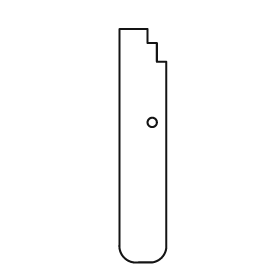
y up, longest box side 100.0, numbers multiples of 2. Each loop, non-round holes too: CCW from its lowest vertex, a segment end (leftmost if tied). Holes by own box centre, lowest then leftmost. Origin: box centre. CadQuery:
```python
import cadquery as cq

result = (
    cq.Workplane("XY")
    .moveTo(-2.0, -50.0)
    .lineTo(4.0, -50.0)
    .threePointArc((8.0, -48.0), (10.0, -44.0))
    .lineTo(10.0, 36.0)
    .lineTo(6.0, 36.0)
    .lineTo(6.0, 44.0)
    .lineTo(2.0, 44.0)
    .lineTo(2.0, 50.0)
    .lineTo(-10.0, 50.0)
    .lineTo(-10.0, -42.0)
    .threePointArc((-8.0, -48.0), (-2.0, -50.0))
    .close()
    .moveTo(4.0, 10.0)
    .circle(2.0)
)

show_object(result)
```